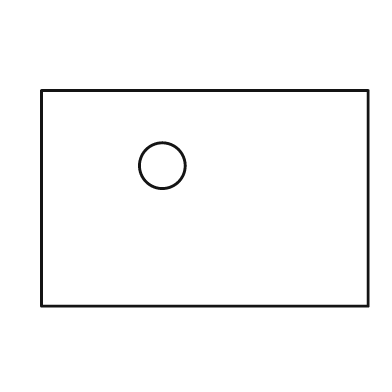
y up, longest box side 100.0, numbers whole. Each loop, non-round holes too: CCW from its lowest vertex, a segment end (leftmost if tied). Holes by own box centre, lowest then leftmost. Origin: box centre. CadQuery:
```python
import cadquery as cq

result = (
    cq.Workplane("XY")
    .moveTo(-50.0, -33.0)
    .lineTo(50.0, -33.0)
    .lineTo(50.0, 33.0)
    .lineTo(-50.0, 33.0)
    .close()
    .moveTo(-13.0, 10.0)
    .circle(7.0)
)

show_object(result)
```